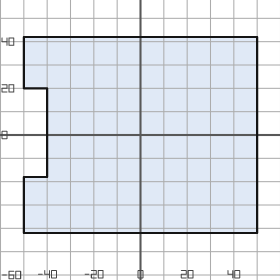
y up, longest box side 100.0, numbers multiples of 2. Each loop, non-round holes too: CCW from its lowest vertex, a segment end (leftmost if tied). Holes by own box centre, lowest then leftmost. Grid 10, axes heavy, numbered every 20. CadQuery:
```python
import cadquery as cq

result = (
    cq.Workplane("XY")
    .moveTo(-50.0, -42.0)
    .lineTo(50.0, -42.0)
    .lineTo(50.0, 42.0)
    .lineTo(-50.0, 42.0)
    .lineTo(-50.0, 20.0)
    .lineTo(-40.0, 20.0)
    .lineTo(-40.0, -18.0)
    .lineTo(-50.0, -18.0)
    .close()
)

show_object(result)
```